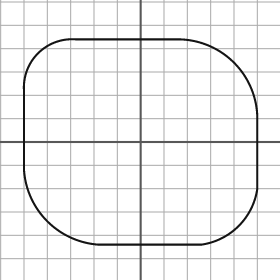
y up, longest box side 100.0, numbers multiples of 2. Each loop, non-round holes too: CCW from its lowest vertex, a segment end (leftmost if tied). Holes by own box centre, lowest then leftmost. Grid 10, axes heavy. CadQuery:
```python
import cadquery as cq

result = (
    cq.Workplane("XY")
    .moveTo(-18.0, -44.0)
    .lineTo(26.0, -44.0)
    .threePointArc((42.0, -36.0), (50.0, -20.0))
    .lineTo(50.0, 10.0)
    .threePointArc((40.0, 34.0), (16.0, 44.0))
    .lineTo(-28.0, 44.0)
    .threePointArc((-44.0, 38.0), (-50.0, 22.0))
    .lineTo(-50.0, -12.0)
    .threePointArc((-40.0, -34.0), (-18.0, -44.0))
    .close()
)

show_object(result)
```